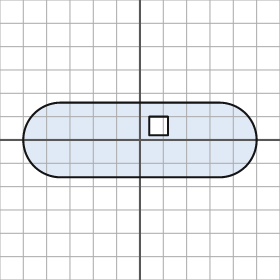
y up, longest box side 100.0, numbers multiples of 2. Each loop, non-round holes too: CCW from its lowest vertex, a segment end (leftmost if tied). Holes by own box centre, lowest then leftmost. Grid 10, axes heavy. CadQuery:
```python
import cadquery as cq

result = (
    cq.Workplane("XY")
    .moveTo(-34.0, -16.0)
    .lineTo(34.0, -16.0)
    .threePointArc((50.0, 0.0), (34.0, 16.0))
    .lineTo(-34.0, 16.0)
    .threePointArc((-50.0, 0.0), (-34.0, -16.0))
    .close()
    .moveTo(4.0, 2.0)
    .lineTo(12.0, 2.0)
    .lineTo(12.0, 10.0)
    .lineTo(4.0, 10.0)
    .close()
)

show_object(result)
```